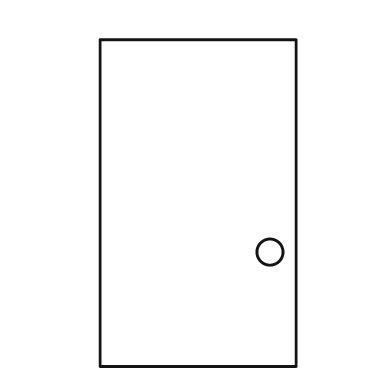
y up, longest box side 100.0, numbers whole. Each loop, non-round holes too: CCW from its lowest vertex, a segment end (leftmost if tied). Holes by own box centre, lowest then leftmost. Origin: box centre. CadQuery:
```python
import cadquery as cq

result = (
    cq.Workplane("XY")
    .moveTo(-30.0, -50.0)
    .lineTo(30.0, -50.0)
    .lineTo(30.0, 50.0)
    .lineTo(-30.0, 50.0)
    .close()
    .moveTo(22.0, -15.0)
    .circle(4.0)
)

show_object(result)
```